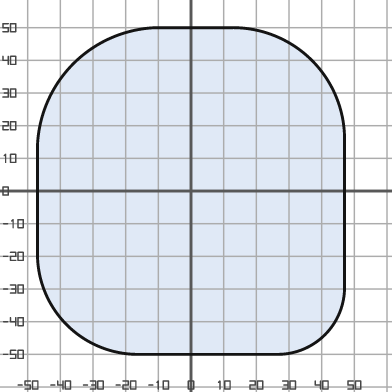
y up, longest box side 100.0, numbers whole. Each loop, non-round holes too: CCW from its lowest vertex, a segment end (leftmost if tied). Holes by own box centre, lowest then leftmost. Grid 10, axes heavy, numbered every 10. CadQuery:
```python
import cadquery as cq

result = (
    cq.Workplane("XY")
    .moveTo(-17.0, -50.0)
    .lineTo(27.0, -50.0)
    .threePointArc((41.0, -44.0), (47.0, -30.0))
    .lineTo(47.0, 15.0)
    .threePointArc((37.0, 40.0), (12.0, 50.0))
    .lineTo(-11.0, 50.0)
    .threePointArc((-36.0, 39.0), (-47.0, 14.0))
    .lineTo(-47.0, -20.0)
    .threePointArc((-38.0, -41.0), (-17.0, -50.0))
    .close()
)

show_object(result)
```